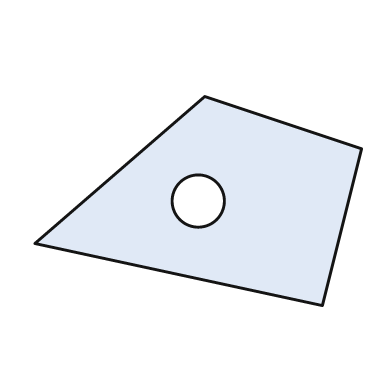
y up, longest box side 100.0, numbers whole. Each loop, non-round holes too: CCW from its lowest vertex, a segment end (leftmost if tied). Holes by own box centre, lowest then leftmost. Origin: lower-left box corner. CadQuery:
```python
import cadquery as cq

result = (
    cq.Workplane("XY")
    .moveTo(88.0, 0.0)
    .lineTo(100.0, 48.0)
    .lineTo(52.0, 64.0)
    .lineTo(0.0, 19.0)
    .close()
    .moveTo(50.0, 32.0)
    .circle(8.0)
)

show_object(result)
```